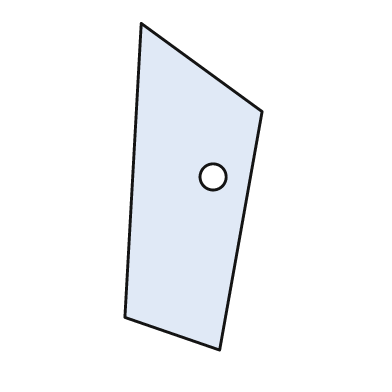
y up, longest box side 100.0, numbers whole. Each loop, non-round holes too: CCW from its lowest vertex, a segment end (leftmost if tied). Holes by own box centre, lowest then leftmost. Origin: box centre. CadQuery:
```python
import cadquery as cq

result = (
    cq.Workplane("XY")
    .moveTo(8.0, -50.0)
    .lineTo(21.0, 23.0)
    .lineTo(-16.0, 50.0)
    .lineTo(-21.0, -40.0)
    .close()
    .moveTo(6.0, 3.0)
    .circle(4.0)
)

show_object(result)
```